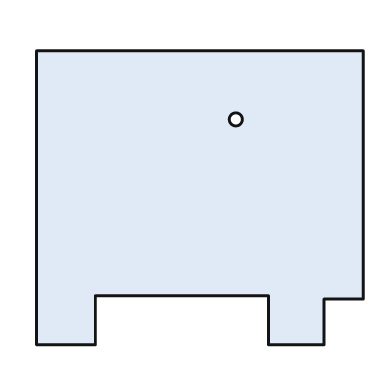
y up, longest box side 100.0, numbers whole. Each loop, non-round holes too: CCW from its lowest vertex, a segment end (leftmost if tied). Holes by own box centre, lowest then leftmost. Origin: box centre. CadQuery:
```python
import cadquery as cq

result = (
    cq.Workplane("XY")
    .moveTo(-50.0, -45.0)
    .lineTo(-32.0, -45.0)
    .lineTo(-32.0, -30.0)
    .lineTo(21.0, -30.0)
    .lineTo(21.0, -45.0)
    .lineTo(38.0, -45.0)
    .lineTo(38.0, -31.0)
    .lineTo(50.0, -31.0)
    .lineTo(50.0, 45.0)
    .lineTo(-50.0, 45.0)
    .close()
    .moveTo(11.0, 24.0)
    .circle(2.0)
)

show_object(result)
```